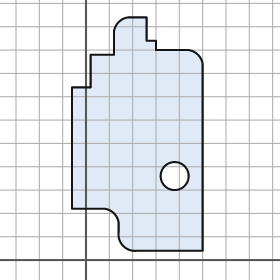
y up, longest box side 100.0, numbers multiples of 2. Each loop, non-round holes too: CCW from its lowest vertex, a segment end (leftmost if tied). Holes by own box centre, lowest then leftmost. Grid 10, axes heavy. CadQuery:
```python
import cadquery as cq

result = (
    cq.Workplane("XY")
    .moveTo(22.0, 4.0)
    .lineTo(50.0, 4.0)
    .lineTo(50.0, 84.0)
    .threePointArc((48.0, 88.0), (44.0, 90.0))
    .lineTo(30.0, 90.0)
    .lineTo(30.0, 94.0)
    .lineTo(26.0, 94.0)
    .lineTo(26.0, 104.0)
    .lineTo(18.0, 104.0)
    .threePointArc((14.0, 102.0), (12.0, 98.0))
    .lineTo(12.0, 88.0)
    .lineTo(2.0, 88.0)
    .lineTo(2.0, 74.0)
    .lineTo(-6.0, 74.0)
    .lineTo(-6.0, 22.0)
    .lineTo(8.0, 22.0)
    .threePointArc((12.0, 20.0), (14.0, 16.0))
    .lineTo(14.0, 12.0)
    .threePointArc((16.0, 6.0), (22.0, 4.0))
    .close()
    .moveTo(38.0, 36.0)
    .circle(6.0)
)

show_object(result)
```